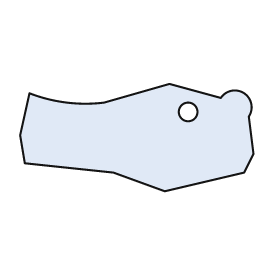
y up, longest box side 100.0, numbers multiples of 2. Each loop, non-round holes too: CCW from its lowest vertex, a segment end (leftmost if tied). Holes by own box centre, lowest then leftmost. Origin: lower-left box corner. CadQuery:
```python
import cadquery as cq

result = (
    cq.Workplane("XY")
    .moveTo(62.0, 0.0)
    .lineTo(96.0, 8.0)
    .lineTo(100.0, 16.0)
    .lineTo(98.0, 32.0)
    .threePointArc((96.0, 42.0), (86.0, 40.0))
    .lineTo(64.0, 46.0)
    .lineTo(36.0, 38.0)
    .threePointArc((20.0, 38.0), (4.0, 42.0))
    .lineTo(0.0, 24.0)
    .lineTo(2.0, 12.0)
    .lineTo(40.0, 8.0)
    .close()
    .moveTo(72.0, 34.0)
    .circle(4.0)
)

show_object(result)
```